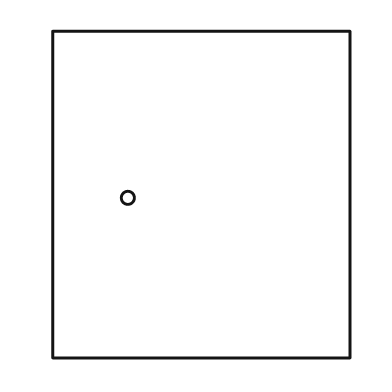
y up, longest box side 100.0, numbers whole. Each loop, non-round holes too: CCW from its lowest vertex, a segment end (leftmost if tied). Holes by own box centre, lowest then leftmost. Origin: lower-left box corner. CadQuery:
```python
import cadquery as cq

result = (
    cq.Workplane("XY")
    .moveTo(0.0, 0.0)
    .lineTo(91.0, 0.0)
    .lineTo(91.0, 100.0)
    .lineTo(0.0, 100.0)
    .close()
    .moveTo(23.0, 49.0)
    .circle(2.0)
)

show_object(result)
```